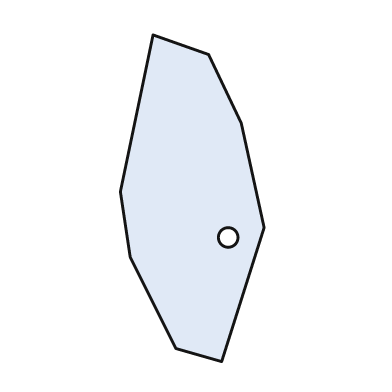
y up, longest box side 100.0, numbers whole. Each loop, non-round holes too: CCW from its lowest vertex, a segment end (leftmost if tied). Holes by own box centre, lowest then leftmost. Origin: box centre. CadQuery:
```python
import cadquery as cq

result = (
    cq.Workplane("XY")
    .moveTo(9.0, -50.0)
    .lineTo(22.0, -9.0)
    .lineTo(15.0, 23.0)
    .lineTo(5.0, 44.0)
    .lineTo(-12.0, 50.0)
    .lineTo(-22.0, 2.0)
    .lineTo(-19.0, -18.0)
    .lineTo(-5.0, -46.0)
    .close()
    .moveTo(11.0, -12.0)
    .circle(3.0)
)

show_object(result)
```